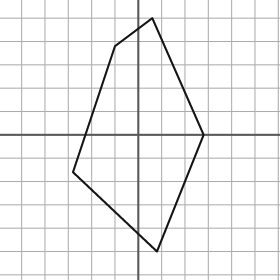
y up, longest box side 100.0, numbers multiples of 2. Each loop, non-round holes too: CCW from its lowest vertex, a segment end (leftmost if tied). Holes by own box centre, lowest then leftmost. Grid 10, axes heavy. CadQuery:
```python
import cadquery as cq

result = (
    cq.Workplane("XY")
    .moveTo(8.0, -50.0)
    .lineTo(28.0, 0.0)
    .lineTo(6.0, 50.0)
    .lineTo(-10.0, 38.0)
    .lineTo(-28.0, -16.0)
    .close()
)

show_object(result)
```